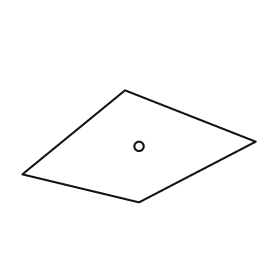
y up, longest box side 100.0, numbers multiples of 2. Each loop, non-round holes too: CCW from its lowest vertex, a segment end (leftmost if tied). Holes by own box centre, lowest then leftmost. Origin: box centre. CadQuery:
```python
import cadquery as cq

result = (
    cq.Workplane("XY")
    .moveTo(0.0, -24.0)
    .lineTo(50.0, 2.0)
    .lineTo(-6.0, 24.0)
    .lineTo(-50.0, -12.0)
    .close()
    .moveTo(0.0, 0.0)
    .circle(2.0)
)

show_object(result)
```